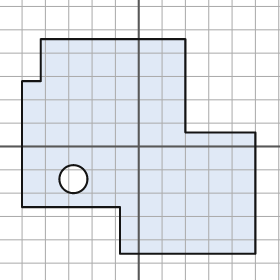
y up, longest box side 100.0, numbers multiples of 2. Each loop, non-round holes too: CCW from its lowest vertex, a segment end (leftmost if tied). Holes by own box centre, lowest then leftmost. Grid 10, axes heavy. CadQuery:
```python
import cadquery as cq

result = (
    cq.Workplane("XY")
    .moveTo(-8.0, -46.0)
    .lineTo(50.0, -46.0)
    .lineTo(50.0, 6.0)
    .lineTo(20.0, 6.0)
    .lineTo(20.0, 46.0)
    .lineTo(-42.0, 46.0)
    .lineTo(-42.0, 28.0)
    .lineTo(-50.0, 28.0)
    .lineTo(-50.0, -26.0)
    .lineTo(-8.0, -26.0)
    .close()
    .moveTo(-28.0, -14.0)
    .circle(6.0)
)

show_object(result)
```